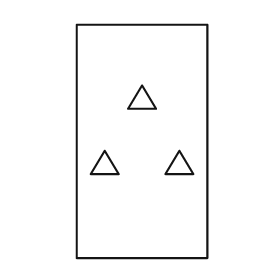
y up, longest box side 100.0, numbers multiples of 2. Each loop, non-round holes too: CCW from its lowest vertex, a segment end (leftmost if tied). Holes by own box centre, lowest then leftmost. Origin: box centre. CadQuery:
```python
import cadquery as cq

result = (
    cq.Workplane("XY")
    .moveTo(-28.0, -50.0)
    .lineTo(28.0, -50.0)
    .lineTo(28.0, 50.0)
    .lineTo(-28.0, 50.0)
    .close()
    .moveTo(-22.0, -14.0)
    .lineTo(-10.0, -14.0)
    .lineTo(-16.0, -4.0)
    .close()
    .moveTo(10.0, -14.0)
    .lineTo(22.0, -14.0)
    .lineTo(16.0, -4.0)
    .close()
    .moveTo(-6.0, 14.0)
    .lineTo(6.0, 14.0)
    .lineTo(0.0, 24.0)
    .close()
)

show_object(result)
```